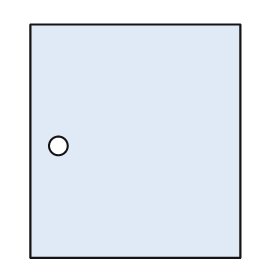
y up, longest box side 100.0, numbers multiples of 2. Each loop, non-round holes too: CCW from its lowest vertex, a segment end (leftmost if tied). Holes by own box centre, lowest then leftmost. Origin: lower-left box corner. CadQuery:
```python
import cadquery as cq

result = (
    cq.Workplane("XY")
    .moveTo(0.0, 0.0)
    .lineTo(90.0, 0.0)
    .lineTo(90.0, 100.0)
    .lineTo(0.0, 100.0)
    .close()
    .moveTo(12.0, 48.0)
    .circle(4.0)
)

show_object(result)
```